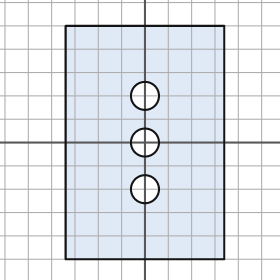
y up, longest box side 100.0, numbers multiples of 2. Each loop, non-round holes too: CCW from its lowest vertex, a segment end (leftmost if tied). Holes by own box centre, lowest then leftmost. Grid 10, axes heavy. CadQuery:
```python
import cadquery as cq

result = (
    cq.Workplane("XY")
    .moveTo(-34.0, -50.0)
    .lineTo(34.0, -50.0)
    .lineTo(34.0, 50.0)
    .lineTo(-34.0, 50.0)
    .close()
    .moveTo(0.0, -20.0)
    .circle(6.0)
    .moveTo(0.0, 0.0)
    .circle(6.0)
    .moveTo(0.0, 20.0)
    .circle(6.0)
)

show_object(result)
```